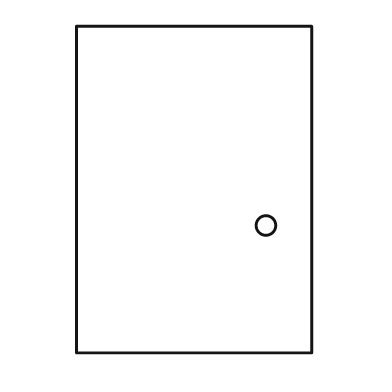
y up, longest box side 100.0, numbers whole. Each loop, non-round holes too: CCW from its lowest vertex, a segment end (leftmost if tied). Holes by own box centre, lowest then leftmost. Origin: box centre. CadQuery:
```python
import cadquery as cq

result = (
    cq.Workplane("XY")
    .moveTo(-36.0, -50.0)
    .lineTo(36.0, -50.0)
    .lineTo(36.0, 50.0)
    .lineTo(-36.0, 50.0)
    .close()
    .moveTo(22.0, -11.0)
    .circle(3.0)
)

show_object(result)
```